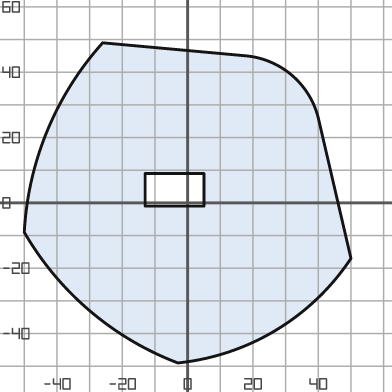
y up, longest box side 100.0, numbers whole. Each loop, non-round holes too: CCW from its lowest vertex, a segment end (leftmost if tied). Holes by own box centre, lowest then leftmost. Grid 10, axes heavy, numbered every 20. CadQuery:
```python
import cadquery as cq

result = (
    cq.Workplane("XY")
    .moveTo(-3.0, -49.0)
    .threePointArc((27.0, -39.0), (50.0, -17.0))
    .lineTo(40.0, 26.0)
    .threePointArc((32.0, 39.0), (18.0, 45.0))
    .lineTo(-26.0, 49.0)
    .threePointArc((-43.0, 22.0), (-50.0, -9.0))
    .threePointArc((-30.0, -33.0), (-3.0, -49.0))
    .close()
    .moveTo(-13.0, -1.0)
    .lineTo(5.0, -1.0)
    .lineTo(5.0, 9.0)
    .lineTo(-13.0, 9.0)
    .close()
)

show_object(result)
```